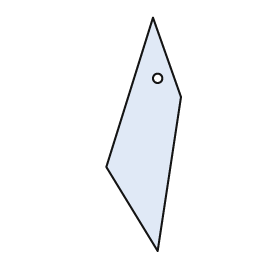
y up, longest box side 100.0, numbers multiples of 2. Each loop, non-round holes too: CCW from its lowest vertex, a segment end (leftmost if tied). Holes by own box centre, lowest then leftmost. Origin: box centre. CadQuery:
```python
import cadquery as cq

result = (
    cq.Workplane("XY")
    .moveTo(6.0, -50.0)
    .lineTo(16.0, 16.0)
    .lineTo(4.0, 50.0)
    .lineTo(-16.0, -14.0)
    .close()
    .moveTo(6.0, 24.0)
    .circle(2.0)
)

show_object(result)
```